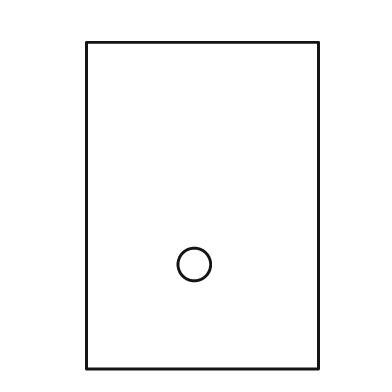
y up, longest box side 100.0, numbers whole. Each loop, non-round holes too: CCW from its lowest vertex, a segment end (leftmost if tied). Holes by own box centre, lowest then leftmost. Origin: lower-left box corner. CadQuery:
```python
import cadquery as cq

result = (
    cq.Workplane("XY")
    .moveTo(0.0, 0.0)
    .lineTo(71.0, 0.0)
    .lineTo(71.0, 100.0)
    .lineTo(0.0, 100.0)
    .close()
    .moveTo(33.0, 32.0)
    .circle(5.0)
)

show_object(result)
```